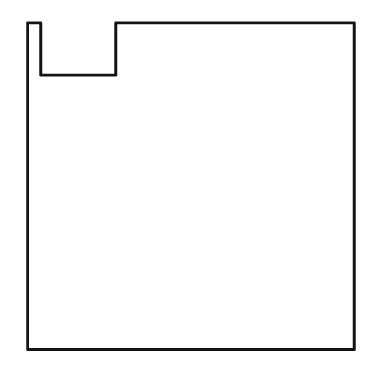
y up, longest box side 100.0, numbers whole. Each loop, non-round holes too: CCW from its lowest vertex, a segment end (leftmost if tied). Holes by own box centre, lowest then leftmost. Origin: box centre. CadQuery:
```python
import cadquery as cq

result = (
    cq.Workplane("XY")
    .moveTo(-50.0, -50.0)
    .lineTo(50.0, -50.0)
    .lineTo(50.0, 50.0)
    .lineTo(-23.0, 50.0)
    .lineTo(-23.0, 34.0)
    .lineTo(-46.0, 34.0)
    .lineTo(-46.0, 50.0)
    .lineTo(-50.0, 50.0)
    .close()
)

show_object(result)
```